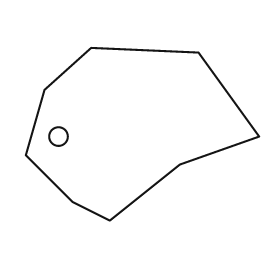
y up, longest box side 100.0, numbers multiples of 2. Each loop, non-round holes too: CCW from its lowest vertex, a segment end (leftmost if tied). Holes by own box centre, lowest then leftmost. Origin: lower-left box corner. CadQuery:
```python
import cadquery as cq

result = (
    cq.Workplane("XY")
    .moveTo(36.0, 0.0)
    .lineTo(66.0, 24.0)
    .lineTo(100.0, 36.0)
    .lineTo(74.0, 72.0)
    .lineTo(28.0, 74.0)
    .lineTo(8.0, 56.0)
    .lineTo(0.0, 28.0)
    .lineTo(20.0, 8.0)
    .close()
    .moveTo(14.0, 36.0)
    .circle(4.0)
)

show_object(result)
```